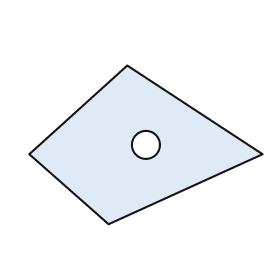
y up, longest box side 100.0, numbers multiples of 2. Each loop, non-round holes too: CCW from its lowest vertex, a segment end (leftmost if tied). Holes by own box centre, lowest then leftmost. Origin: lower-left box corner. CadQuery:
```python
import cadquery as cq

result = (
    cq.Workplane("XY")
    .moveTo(34.0, 0.0)
    .lineTo(100.0, 30.0)
    .lineTo(42.0, 68.0)
    .lineTo(0.0, 30.0)
    .close()
    .moveTo(50.0, 34.0)
    .circle(6.0)
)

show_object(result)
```